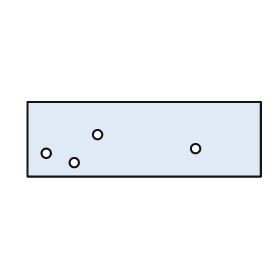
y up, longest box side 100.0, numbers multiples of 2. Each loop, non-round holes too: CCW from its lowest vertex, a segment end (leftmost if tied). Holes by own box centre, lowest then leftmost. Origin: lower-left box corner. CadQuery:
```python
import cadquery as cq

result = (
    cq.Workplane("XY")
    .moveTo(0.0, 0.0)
    .lineTo(100.0, 0.0)
    .lineTo(100.0, 32.0)
    .lineTo(0.0, 32.0)
    .close()
    .moveTo(20.0, 6.0)
    .circle(2.0)
    .moveTo(8.0, 10.0)
    .circle(2.0)
    .moveTo(72.0, 12.0)
    .circle(2.0)
    .moveTo(30.0, 18.0)
    .circle(2.0)
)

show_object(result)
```